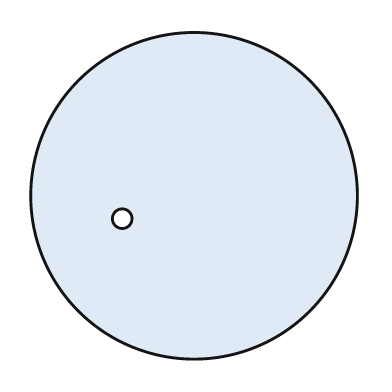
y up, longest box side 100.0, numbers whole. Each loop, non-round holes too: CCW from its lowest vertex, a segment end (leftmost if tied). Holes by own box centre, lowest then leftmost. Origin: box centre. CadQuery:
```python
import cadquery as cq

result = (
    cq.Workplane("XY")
    .moveTo(0.0, 0.0)
    .circle(50.0)
    .moveTo(-22.0, -7.0)
    .circle(3.0)
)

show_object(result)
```